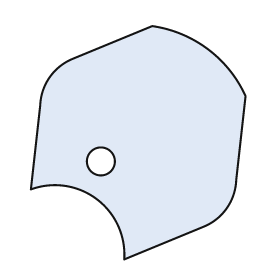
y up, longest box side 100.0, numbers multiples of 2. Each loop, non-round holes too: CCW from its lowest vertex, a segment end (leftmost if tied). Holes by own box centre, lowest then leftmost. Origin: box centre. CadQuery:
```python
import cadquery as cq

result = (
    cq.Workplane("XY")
    .moveTo(-6.0, -50.0)
    .lineTo(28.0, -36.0)
    .threePointArc((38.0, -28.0), (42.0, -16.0))
    .lineTo(46.0, 20.0)
    .threePointArc((30.0, 40.0), (6.0, 50.0))
    .lineTo(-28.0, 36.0)
    .threePointArc((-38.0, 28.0), (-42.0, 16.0))
    .lineTo(-46.0, -20.0)
    .threePointArc((-18.0, -24.0), (-6.0, -50.0))
    .close()
    .moveTo(-16.0, -8.0)
    .circle(6.0)
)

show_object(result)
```